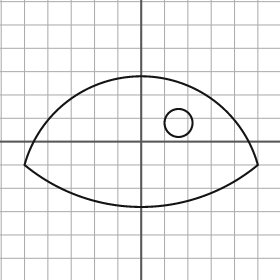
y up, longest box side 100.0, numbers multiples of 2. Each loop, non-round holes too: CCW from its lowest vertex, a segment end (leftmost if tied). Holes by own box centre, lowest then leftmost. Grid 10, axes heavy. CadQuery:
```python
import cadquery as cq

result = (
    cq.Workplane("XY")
    .moveTo(-50.0, -10.0)
    .threePointArc((0.0, -28.0), (50.0, -10.0))
    .threePointArc((0.0, 28.0), (-50.0, -10.0))
    .close()
    .moveTo(16.0, 8.0)
    .circle(6.0)
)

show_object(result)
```